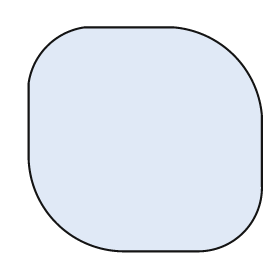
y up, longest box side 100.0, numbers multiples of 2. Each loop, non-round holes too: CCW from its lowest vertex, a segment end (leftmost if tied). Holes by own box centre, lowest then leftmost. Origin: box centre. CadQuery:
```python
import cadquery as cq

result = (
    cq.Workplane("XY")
    .moveTo(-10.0, -48.0)
    .lineTo(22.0, -48.0)
    .threePointArc((42.0, -40.0), (50.0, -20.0))
    .lineTo(50.0, 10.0)
    .threePointArc((38.0, 36.0), (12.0, 48.0))
    .lineTo(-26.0, 48.0)
    .threePointArc((-42.0, 40.0), (-50.0, 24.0))
    .lineTo(-50.0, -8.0)
    .threePointArc((-38.0, -36.0), (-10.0, -48.0))
    .close()
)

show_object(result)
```